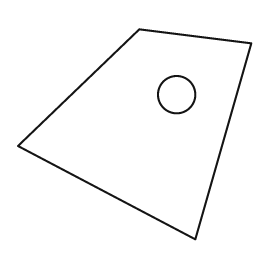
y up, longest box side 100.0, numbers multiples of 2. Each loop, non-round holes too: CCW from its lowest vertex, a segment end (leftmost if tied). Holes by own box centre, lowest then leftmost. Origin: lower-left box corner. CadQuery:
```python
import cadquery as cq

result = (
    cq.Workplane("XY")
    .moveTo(76.0, 0.0)
    .lineTo(100.0, 84.0)
    .lineTo(52.0, 90.0)
    .lineTo(0.0, 40.0)
    .close()
    .moveTo(68.0, 62.0)
    .circle(8.0)
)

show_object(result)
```